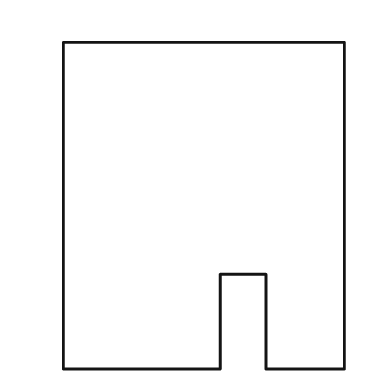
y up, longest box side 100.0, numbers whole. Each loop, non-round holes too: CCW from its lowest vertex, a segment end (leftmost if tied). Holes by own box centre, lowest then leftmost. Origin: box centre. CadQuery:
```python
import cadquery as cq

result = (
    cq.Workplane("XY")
    .moveTo(-43.0, -50.0)
    .lineTo(5.0, -50.0)
    .lineTo(5.0, -21.0)
    .lineTo(19.0, -21.0)
    .lineTo(19.0, -50.0)
    .lineTo(43.0, -50.0)
    .lineTo(43.0, 50.0)
    .lineTo(-43.0, 50.0)
    .close()
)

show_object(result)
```